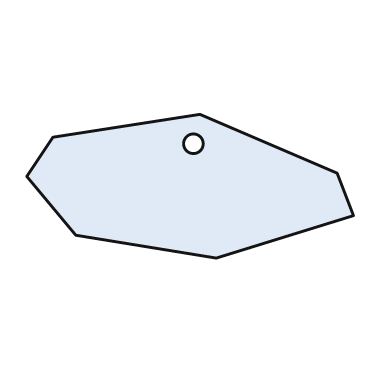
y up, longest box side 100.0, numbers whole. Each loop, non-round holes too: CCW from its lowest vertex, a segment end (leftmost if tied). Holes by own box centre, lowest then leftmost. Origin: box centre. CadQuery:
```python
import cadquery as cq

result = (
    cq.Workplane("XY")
    .moveTo(8.0, -22.0)
    .lineTo(50.0, -9.0)
    .lineTo(45.0, 4.0)
    .lineTo(3.0, 22.0)
    .lineTo(-42.0, 15.0)
    .lineTo(-50.0, 3.0)
    .lineTo(-35.0, -15.0)
    .close()
    .moveTo(1.0, 13.0)
    .circle(3.0)
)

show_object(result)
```